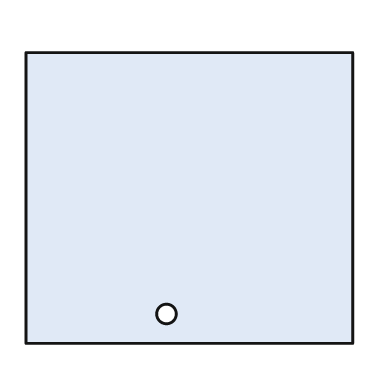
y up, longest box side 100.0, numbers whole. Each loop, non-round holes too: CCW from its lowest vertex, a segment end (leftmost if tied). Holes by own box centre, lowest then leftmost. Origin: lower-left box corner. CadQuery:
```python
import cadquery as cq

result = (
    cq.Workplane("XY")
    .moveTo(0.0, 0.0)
    .lineTo(100.0, 0.0)
    .lineTo(100.0, 89.0)
    .lineTo(0.0, 89.0)
    .close()
    .moveTo(43.0, 9.0)
    .circle(3.0)
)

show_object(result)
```